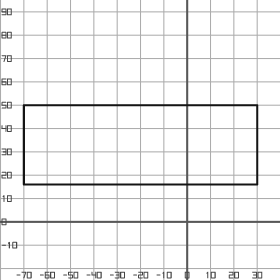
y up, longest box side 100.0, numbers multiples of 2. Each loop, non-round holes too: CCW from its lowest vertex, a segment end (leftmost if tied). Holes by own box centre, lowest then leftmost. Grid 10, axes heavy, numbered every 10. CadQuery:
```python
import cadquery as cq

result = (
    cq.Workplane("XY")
    .moveTo(-70.0, 16.0)
    .lineTo(30.0, 16.0)
    .lineTo(30.0, 50.0)
    .lineTo(-70.0, 50.0)
    .close()
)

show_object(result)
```